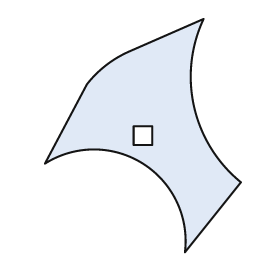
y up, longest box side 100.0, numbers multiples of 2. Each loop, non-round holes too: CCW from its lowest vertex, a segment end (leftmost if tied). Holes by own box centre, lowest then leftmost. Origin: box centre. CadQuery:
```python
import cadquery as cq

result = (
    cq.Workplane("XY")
    .moveTo(18.0, -50.0)
    .lineTo(42.0, -20.0)
    .threePointArc((22.0, 12.0), (26.0, 50.0))
    .lineTo(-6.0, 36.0)
    .threePointArc((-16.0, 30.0), (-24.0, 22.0))
    .lineTo(-42.0, -12.0)
    .threePointArc((0.0, -12.0), (18.0, -50.0))
    .close()
    .moveTo(-4.0, -4.0)
    .lineTo(4.0, -4.0)
    .lineTo(4.0, 4.0)
    .lineTo(-4.0, 4.0)
    .close()
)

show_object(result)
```